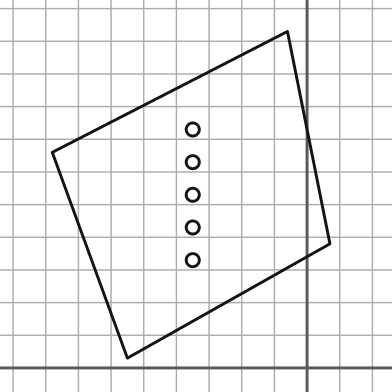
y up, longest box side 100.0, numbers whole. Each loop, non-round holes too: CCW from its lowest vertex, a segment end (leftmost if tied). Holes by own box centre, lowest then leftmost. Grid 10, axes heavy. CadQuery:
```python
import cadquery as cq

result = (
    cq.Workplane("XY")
    .moveTo(-55.0, 3.0)
    .lineTo(7.0, 38.0)
    .lineTo(-6.0, 103.0)
    .lineTo(-78.0, 66.0)
    .close()
    .moveTo(-35.0, 33.0)
    .circle(2.0)
    .moveTo(-35.0, 43.0)
    .circle(2.0)
    .moveTo(-35.0, 53.0)
    .circle(2.0)
    .moveTo(-35.0, 63.0)
    .circle(2.0)
    .moveTo(-35.0, 73.0)
    .circle(2.0)
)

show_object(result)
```